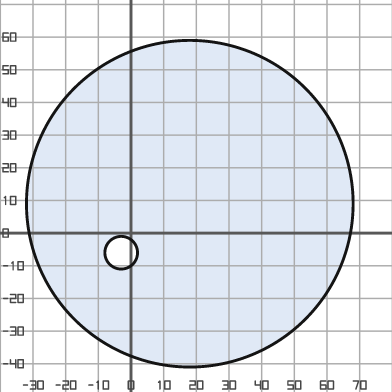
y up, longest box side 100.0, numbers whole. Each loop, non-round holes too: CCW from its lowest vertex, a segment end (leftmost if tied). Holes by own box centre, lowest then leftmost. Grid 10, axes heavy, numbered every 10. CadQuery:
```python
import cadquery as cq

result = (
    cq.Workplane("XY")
    .moveTo(18.0, 9.0)
    .circle(50.0)
    .moveTo(-3.0, -6.0)
    .circle(5.0)
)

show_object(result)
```